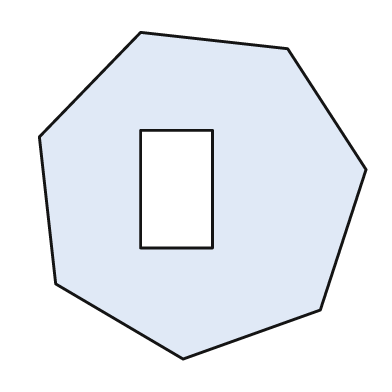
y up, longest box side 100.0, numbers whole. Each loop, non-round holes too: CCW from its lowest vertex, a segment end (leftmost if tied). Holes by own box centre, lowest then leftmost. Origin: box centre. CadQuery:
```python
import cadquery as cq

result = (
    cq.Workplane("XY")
    .moveTo(-6.0, -50.0)
    .lineTo(36.0, -35.0)
    .lineTo(50.0, 8.0)
    .lineTo(26.0, 45.0)
    .lineTo(-19.0, 50.0)
    .lineTo(-50.0, 18.0)
    .lineTo(-45.0, -27.0)
    .close()
    .moveTo(-19.0, -16.0)
    .lineTo(3.0, -16.0)
    .lineTo(3.0, 20.0)
    .lineTo(-19.0, 20.0)
    .close()
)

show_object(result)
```